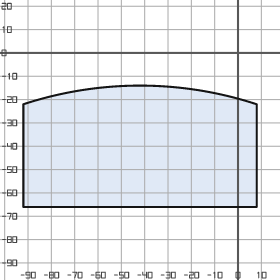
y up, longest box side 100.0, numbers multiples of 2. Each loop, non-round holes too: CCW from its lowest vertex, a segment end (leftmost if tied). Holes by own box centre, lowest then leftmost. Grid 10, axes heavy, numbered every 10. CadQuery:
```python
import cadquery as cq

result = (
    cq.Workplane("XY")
    .moveTo(-92.0, -66.0)
    .lineTo(8.0, -66.0)
    .lineTo(8.0, -22.0)
    .threePointArc((-42.0, -14.0), (-92.0, -22.0))
    .close()
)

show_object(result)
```